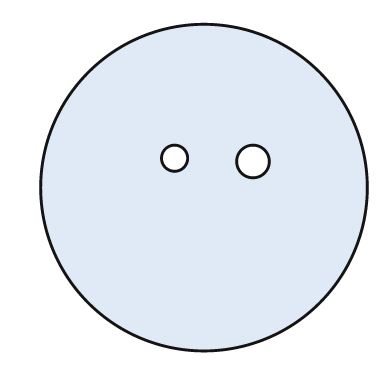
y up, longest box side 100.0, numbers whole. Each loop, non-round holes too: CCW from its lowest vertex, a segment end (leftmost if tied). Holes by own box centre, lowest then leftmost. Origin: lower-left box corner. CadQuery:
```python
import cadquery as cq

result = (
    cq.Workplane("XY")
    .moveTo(50.0, 50.0)
    .circle(50.0)
    .moveTo(65.0, 58.0)
    .circle(5.0)
    .moveTo(41.0, 59.0)
    .circle(4.0)
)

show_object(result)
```